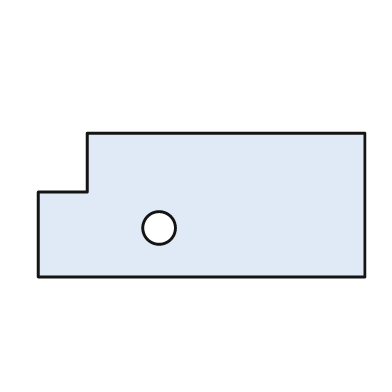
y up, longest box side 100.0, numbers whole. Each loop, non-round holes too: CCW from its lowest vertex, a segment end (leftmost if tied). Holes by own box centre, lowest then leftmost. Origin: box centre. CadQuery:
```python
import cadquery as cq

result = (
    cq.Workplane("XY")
    .moveTo(-50.0, -22.0)
    .lineTo(50.0, -22.0)
    .lineTo(50.0, 22.0)
    .lineTo(-35.0, 22.0)
    .lineTo(-35.0, 4.0)
    .lineTo(-50.0, 4.0)
    .close()
    .moveTo(-13.0, -7.0)
    .circle(5.0)
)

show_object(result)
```